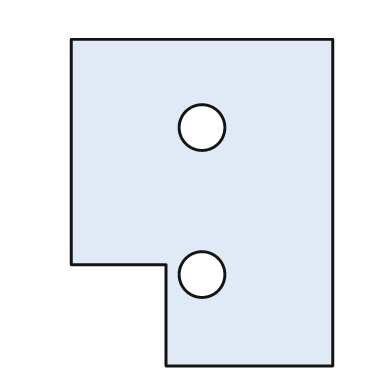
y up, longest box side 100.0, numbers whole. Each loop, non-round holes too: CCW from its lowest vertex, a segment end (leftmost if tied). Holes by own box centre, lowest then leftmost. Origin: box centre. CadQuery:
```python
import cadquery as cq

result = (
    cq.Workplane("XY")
    .moveTo(-11.0, -50.0)
    .lineTo(40.0, -50.0)
    .lineTo(40.0, 50.0)
    .lineTo(-40.0, 50.0)
    .lineTo(-40.0, -19.0)
    .lineTo(-11.0, -19.0)
    .close()
    .moveTo(0.0, -22.0)
    .circle(7.0)
    .moveTo(0.0, 23.0)
    .circle(7.0)
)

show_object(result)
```